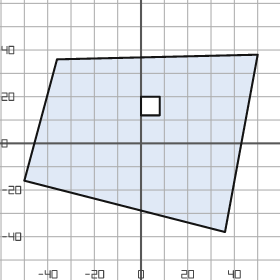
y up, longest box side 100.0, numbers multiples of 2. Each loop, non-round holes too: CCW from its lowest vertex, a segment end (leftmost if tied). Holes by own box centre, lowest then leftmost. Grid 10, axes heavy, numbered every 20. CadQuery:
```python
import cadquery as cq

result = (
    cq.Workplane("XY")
    .moveTo(36.0, -38.0)
    .lineTo(50.0, 38.0)
    .lineTo(-36.0, 36.0)
    .lineTo(-50.0, -16.0)
    .close()
    .moveTo(0.0, 12.0)
    .lineTo(8.0, 12.0)
    .lineTo(8.0, 20.0)
    .lineTo(0.0, 20.0)
    .close()
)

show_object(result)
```